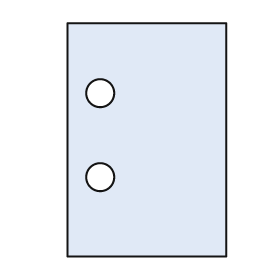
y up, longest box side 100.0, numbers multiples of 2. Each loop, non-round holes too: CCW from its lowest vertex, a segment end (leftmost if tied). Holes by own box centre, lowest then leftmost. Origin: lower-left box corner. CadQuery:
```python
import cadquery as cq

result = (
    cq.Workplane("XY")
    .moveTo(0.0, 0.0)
    .lineTo(68.0, 0.0)
    .lineTo(68.0, 100.0)
    .lineTo(0.0, 100.0)
    .close()
    .moveTo(14.0, 34.0)
    .circle(6.0)
    .moveTo(14.0, 70.0)
    .circle(6.0)
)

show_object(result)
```